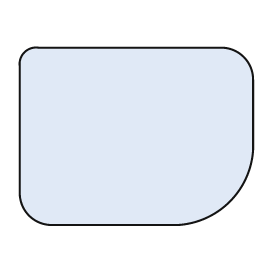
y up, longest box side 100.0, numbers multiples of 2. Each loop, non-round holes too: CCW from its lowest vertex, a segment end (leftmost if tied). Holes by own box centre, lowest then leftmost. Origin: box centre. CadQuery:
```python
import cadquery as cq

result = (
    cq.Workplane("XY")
    .moveTo(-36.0, -38.0)
    .lineTo(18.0, -38.0)
    .threePointArc((40.0, -28.0), (50.0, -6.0))
    .lineTo(50.0, 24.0)
    .threePointArc((46.0, 34.0), (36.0, 38.0))
    .lineTo(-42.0, 38.0)
    .threePointArc((-48.0, 36.0), (-50.0, 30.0))
    .lineTo(-50.0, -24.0)
    .threePointArc((-46.0, -34.0), (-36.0, -38.0))
    .close()
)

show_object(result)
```